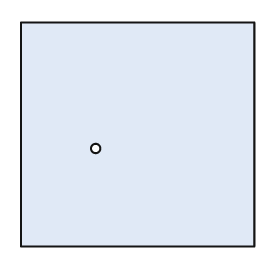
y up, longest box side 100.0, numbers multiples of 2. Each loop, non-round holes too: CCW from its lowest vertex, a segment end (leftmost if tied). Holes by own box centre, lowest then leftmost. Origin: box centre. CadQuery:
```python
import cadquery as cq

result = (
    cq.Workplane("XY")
    .moveTo(-50.0, -48.0)
    .lineTo(50.0, -48.0)
    .lineTo(50.0, 48.0)
    .lineTo(-50.0, 48.0)
    .close()
    .moveTo(-18.0, -6.0)
    .circle(2.0)
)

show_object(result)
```